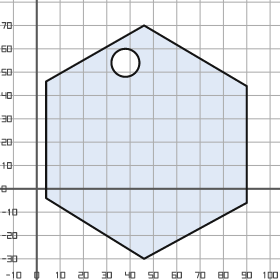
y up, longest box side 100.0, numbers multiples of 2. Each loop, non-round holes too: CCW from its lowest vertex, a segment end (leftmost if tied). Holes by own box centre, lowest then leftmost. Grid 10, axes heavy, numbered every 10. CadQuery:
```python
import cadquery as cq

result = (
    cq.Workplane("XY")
    .moveTo(46.0, -30.0)
    .lineTo(90.0, -6.0)
    .lineTo(90.0, 44.0)
    .lineTo(46.0, 70.0)
    .lineTo(4.0, 46.0)
    .lineTo(4.0, -4.0)
    .close()
    .moveTo(38.0, 54.0)
    .circle(6.0)
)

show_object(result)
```